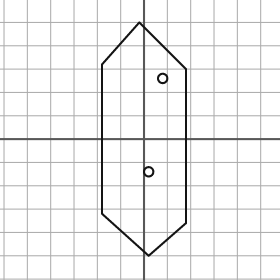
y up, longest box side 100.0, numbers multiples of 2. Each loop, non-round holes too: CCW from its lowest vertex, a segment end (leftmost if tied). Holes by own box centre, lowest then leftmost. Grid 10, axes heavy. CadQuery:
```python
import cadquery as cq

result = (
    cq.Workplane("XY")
    .moveTo(2.0, -50.0)
    .lineTo(18.0, -36.0)
    .lineTo(18.0, 30.0)
    .lineTo(-2.0, 50.0)
    .lineTo(-18.0, 32.0)
    .lineTo(-18.0, -32.0)
    .close()
    .moveTo(2.0, -14.0)
    .circle(2.0)
    .moveTo(8.0, 26.0)
    .circle(2.0)
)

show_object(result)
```